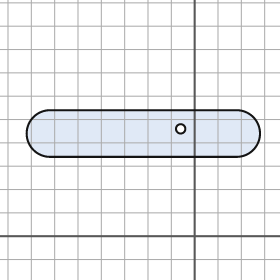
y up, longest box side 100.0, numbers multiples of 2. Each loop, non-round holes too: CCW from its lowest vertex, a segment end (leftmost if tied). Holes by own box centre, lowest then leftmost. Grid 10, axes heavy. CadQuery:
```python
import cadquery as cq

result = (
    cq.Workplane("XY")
    .moveTo(-62.0, 34.0)
    .lineTo(18.0, 34.0)
    .threePointArc((28.0, 44.0), (18.0, 54.0))
    .lineTo(-62.0, 54.0)
    .threePointArc((-72.0, 44.0), (-62.0, 34.0))
    .close()
    .moveTo(-6.0, 46.0)
    .circle(2.0)
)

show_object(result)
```